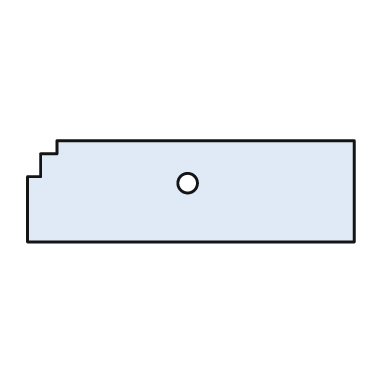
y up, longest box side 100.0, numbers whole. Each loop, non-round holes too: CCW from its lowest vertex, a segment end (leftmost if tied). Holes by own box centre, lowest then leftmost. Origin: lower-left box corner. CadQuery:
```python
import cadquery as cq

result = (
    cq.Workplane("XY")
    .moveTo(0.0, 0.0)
    .lineTo(100.0, 0.0)
    .lineTo(100.0, 31.0)
    .lineTo(9.0, 31.0)
    .lineTo(9.0, 27.0)
    .lineTo(4.0, 27.0)
    .lineTo(4.0, 20.0)
    .lineTo(0.0, 20.0)
    .close()
    .moveTo(49.0, 18.0)
    .circle(3.0)
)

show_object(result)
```